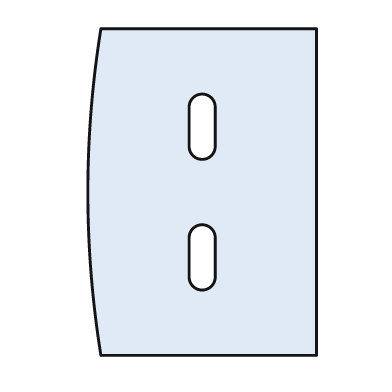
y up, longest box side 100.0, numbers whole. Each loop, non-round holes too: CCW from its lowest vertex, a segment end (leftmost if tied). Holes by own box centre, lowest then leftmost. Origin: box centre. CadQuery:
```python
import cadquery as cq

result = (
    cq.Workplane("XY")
    .moveTo(-31.0, -50.0)
    .lineTo(35.0, -50.0)
    .lineTo(35.0, 50.0)
    .lineTo(-31.0, 50.0)
    .threePointArc((-35.0, 0.0), (-31.0, -50.0))
    .close()
    .moveTo(-4.0, -26.0)
    .threePointArc((0.0, -30.0), (4.0, -26.0))
    .lineTo(4.0, -14.0)
    .threePointArc((0.0, -10.0), (-4.0, -14.0))
    .close()
    .moveTo(-4.0, 14.0)
    .threePointArc((0.0, 10.0), (4.0, 14.0))
    .lineTo(4.0, 26.0)
    .threePointArc((0.0, 30.0), (-4.0, 26.0))
    .close()
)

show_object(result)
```